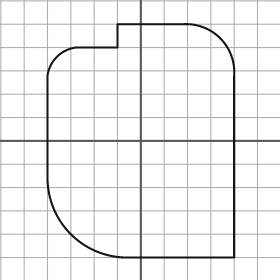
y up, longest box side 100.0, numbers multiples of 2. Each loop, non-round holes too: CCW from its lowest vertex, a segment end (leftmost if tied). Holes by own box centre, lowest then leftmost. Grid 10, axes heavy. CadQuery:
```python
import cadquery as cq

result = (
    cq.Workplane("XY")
    .moveTo(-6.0, -50.0)
    .lineTo(40.0, -50.0)
    .lineTo(40.0, 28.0)
    .threePointArc((34.0, 44.0), (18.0, 50.0))
    .lineTo(-10.0, 50.0)
    .lineTo(-10.0, 40.0)
    .lineTo(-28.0, 40.0)
    .threePointArc((-36.0, 36.0), (-40.0, 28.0))
    .lineTo(-40.0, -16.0)
    .threePointArc((-30.0, -40.0), (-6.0, -50.0))
    .close()
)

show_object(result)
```